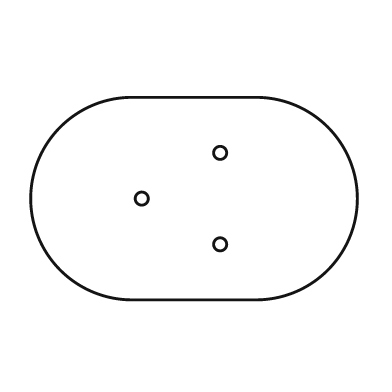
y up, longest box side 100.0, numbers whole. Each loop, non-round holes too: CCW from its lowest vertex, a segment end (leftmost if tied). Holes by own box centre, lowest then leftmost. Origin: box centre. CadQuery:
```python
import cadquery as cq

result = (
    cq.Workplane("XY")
    .moveTo(-19.0, -31.0)
    .lineTo(19.0, -31.0)
    .threePointArc((50.0, 0.0), (19.0, 31.0))
    .lineTo(-19.0, 31.0)
    .threePointArc((-50.0, 0.0), (-19.0, -31.0))
    .close()
    .moveTo(8.0, -14.0)
    .circle(2.0)
    .moveTo(-16.0, 0.0)
    .circle(2.0)
    .moveTo(8.0, 14.0)
    .circle(2.0)
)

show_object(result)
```